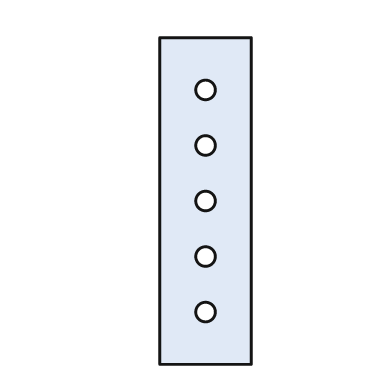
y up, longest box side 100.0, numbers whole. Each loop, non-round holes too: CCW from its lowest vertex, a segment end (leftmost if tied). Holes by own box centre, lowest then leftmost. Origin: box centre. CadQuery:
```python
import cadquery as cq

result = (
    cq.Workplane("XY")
    .moveTo(-14.0, -50.0)
    .lineTo(14.0, -50.0)
    .lineTo(14.0, 50.0)
    .lineTo(-14.0, 50.0)
    .close()
    .moveTo(0.0, -34.0)
    .circle(3.0)
    .moveTo(0.0, -17.0)
    .circle(3.0)
    .moveTo(0.0, 0.0)
    .circle(3.0)
    .moveTo(0.0, 17.0)
    .circle(3.0)
    .moveTo(0.0, 34.0)
    .circle(3.0)
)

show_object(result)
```